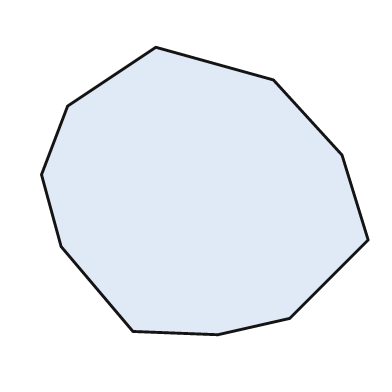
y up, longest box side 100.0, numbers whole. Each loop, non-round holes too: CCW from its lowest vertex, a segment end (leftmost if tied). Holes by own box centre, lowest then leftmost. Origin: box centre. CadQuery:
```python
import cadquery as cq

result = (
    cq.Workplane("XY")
    .moveTo(4.0, -44.0)
    .lineTo(26.0, -39.0)
    .lineTo(50.0, -15.0)
    .lineTo(42.0, 11.0)
    .lineTo(21.0, 34.0)
    .lineTo(-15.0, 44.0)
    .lineTo(-42.0, 26.0)
    .lineTo(-50.0, 5.0)
    .lineTo(-44.0, -17.0)
    .lineTo(-22.0, -43.0)
    .close()
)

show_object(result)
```